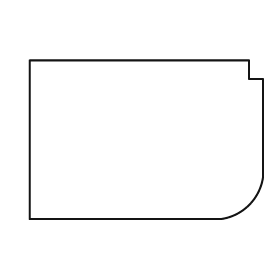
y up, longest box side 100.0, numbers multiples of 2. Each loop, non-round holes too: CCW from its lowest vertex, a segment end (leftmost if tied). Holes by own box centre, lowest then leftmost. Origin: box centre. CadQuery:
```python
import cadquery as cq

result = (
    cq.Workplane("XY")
    .moveTo(-50.0, -34.0)
    .lineTo(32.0, -34.0)
    .threePointArc((44.0, -28.0), (50.0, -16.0))
    .lineTo(50.0, 26.0)
    .lineTo(44.0, 26.0)
    .lineTo(44.0, 34.0)
    .lineTo(-50.0, 34.0)
    .close()
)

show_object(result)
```